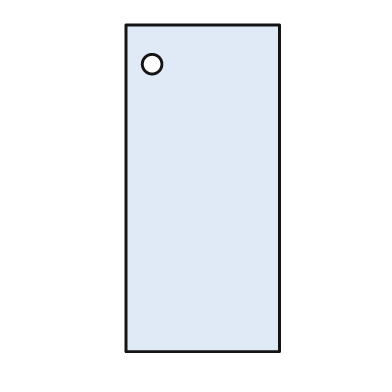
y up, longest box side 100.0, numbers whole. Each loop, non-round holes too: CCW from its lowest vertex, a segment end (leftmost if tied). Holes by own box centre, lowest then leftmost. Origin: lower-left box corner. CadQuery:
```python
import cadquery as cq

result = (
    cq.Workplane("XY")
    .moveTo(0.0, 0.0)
    .lineTo(47.0, 0.0)
    .lineTo(47.0, 100.0)
    .lineTo(0.0, 100.0)
    .close()
    .moveTo(8.0, 88.0)
    .circle(3.0)
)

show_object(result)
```